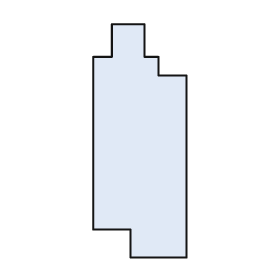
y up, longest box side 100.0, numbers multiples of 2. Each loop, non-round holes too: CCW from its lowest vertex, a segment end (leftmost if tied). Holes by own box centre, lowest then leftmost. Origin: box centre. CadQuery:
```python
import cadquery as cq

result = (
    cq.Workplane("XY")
    .moveTo(-4.0, -50.0)
    .lineTo(20.0, -50.0)
    .lineTo(20.0, 28.0)
    .lineTo(8.0, 28.0)
    .lineTo(8.0, 36.0)
    .lineTo(2.0, 36.0)
    .lineTo(2.0, 50.0)
    .lineTo(-12.0, 50.0)
    .lineTo(-12.0, 36.0)
    .lineTo(-20.0, 36.0)
    .lineTo(-20.0, -38.0)
    .lineTo(-4.0, -38.0)
    .close()
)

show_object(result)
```